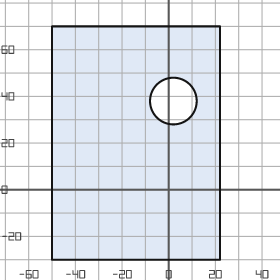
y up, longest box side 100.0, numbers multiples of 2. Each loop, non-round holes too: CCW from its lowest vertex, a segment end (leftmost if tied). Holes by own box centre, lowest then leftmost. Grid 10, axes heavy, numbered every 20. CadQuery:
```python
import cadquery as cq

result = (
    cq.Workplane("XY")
    .moveTo(-50.0, -30.0)
    .lineTo(22.0, -30.0)
    .lineTo(22.0, 70.0)
    .lineTo(-50.0, 70.0)
    .close()
    .moveTo(2.0, 38.0)
    .circle(10.0)
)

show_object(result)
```